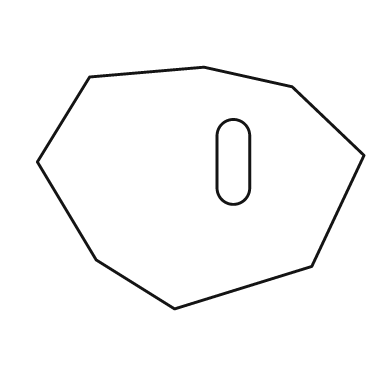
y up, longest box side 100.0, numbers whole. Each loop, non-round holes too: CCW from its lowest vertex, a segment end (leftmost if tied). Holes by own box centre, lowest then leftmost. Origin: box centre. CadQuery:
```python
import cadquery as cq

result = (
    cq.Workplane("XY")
    .moveTo(-8.0, -37.0)
    .lineTo(34.0, -24.0)
    .lineTo(50.0, 10.0)
    .lineTo(28.0, 31.0)
    .lineTo(1.0, 37.0)
    .lineTo(-34.0, 34.0)
    .lineTo(-50.0, 8.0)
    .lineTo(-32.0, -22.0)
    .close()
    .moveTo(5.0, 0.0)
    .threePointArc((10.0, -5.0), (15.0, 0.0))
    .lineTo(15.0, 16.0)
    .threePointArc((10.0, 21.0), (5.0, 16.0))
    .close()
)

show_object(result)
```